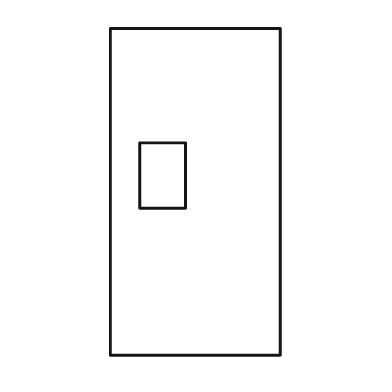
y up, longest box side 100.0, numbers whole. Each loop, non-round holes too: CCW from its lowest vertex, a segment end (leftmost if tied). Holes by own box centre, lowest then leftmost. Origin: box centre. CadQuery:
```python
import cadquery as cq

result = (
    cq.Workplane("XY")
    .moveTo(-26.0, -50.0)
    .lineTo(26.0, -50.0)
    .lineTo(26.0, 50.0)
    .lineTo(-26.0, 50.0)
    .close()
    .moveTo(-17.0, -5.0)
    .lineTo(-3.0, -5.0)
    .lineTo(-3.0, 15.0)
    .lineTo(-17.0, 15.0)
    .close()
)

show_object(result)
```